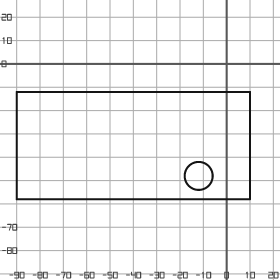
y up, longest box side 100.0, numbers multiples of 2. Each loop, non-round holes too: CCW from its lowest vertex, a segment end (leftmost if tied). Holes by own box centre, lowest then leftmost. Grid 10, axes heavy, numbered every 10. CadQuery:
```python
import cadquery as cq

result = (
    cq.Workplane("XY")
    .moveTo(-90.0, -58.0)
    .lineTo(10.0, -58.0)
    .lineTo(10.0, -12.0)
    .lineTo(-90.0, -12.0)
    .close()
    .moveTo(-12.0, -48.0)
    .circle(6.0)
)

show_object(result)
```